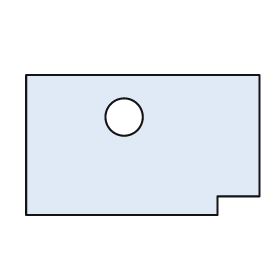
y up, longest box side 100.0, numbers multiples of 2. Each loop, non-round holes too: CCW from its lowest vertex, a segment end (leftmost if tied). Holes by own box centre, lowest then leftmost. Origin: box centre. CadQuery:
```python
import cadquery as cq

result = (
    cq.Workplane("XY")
    .moveTo(-50.0, -30.0)
    .lineTo(32.0, -30.0)
    .lineTo(32.0, -22.0)
    .lineTo(50.0, -22.0)
    .lineTo(50.0, 30.0)
    .lineTo(-50.0, 30.0)
    .close()
    .moveTo(-8.0, 12.0)
    .circle(8.0)
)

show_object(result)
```